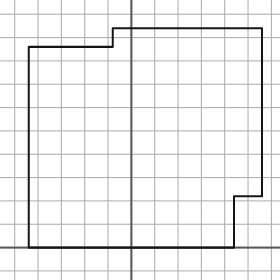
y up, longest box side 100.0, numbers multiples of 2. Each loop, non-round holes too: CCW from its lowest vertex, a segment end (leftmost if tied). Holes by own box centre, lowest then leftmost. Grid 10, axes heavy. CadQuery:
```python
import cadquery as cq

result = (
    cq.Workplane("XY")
    .moveTo(-44.0, 0.0)
    .lineTo(44.0, 0.0)
    .lineTo(44.0, 22.0)
    .lineTo(56.0, 22.0)
    .lineTo(56.0, 94.0)
    .lineTo(-8.0, 94.0)
    .lineTo(-8.0, 86.0)
    .lineTo(-44.0, 86.0)
    .close()
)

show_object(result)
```